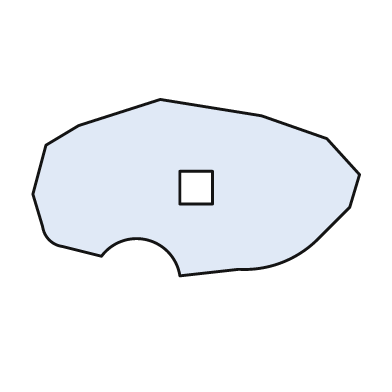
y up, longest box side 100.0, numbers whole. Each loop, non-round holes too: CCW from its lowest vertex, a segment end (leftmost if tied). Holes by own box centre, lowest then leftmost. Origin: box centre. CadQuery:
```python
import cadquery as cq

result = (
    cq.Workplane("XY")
    .moveTo(-5.0, -27.0)
    .lineTo(13.0, -25.0)
    .threePointArc((26.0, -23.0), (37.0, -16.0))
    .lineTo(47.0, -6.0)
    .lineTo(50.0, 4.0)
    .lineTo(40.0, 15.0)
    .lineTo(20.0, 22.0)
    .lineTo(-11.0, 27.0)
    .lineTo(-36.0, 19.0)
    .lineTo(-46.0, 13.0)
    .lineTo(-50.0, -2.0)
    .lineTo(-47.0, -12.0)
    .threePointArc((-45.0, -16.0), (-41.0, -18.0))
    .lineTo(-29.0, -21.0)
    .threePointArc((-15.0, -16.0), (-5.0, -27.0))
    .close()
    .moveTo(-5.0, -5.0)
    .lineTo(5.0, -5.0)
    .lineTo(5.0, 5.0)
    .lineTo(-5.0, 5.0)
    .close()
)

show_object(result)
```